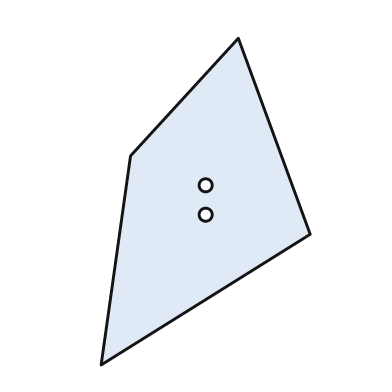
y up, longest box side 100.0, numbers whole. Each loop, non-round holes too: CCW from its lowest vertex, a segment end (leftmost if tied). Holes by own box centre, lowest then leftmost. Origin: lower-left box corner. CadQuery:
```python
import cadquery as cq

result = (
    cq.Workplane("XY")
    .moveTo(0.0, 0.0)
    .lineTo(64.0, 40.0)
    .lineTo(42.0, 100.0)
    .lineTo(9.0, 64.0)
    .close()
    .moveTo(32.0, 46.0)
    .circle(2.0)
    .moveTo(32.0, 55.0)
    .circle(2.0)
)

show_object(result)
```